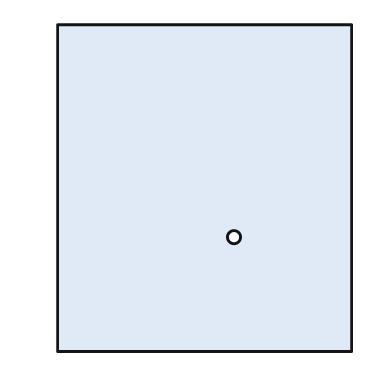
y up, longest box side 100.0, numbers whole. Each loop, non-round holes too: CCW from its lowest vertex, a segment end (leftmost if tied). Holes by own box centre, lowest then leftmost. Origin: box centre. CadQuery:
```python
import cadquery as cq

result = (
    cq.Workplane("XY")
    .moveTo(-45.0, -50.0)
    .lineTo(45.0, -50.0)
    .lineTo(45.0, 50.0)
    .lineTo(-45.0, 50.0)
    .close()
    .moveTo(9.0, -15.0)
    .circle(2.0)
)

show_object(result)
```